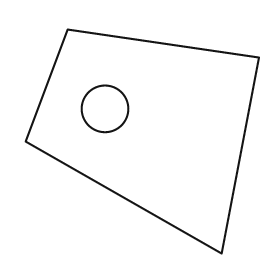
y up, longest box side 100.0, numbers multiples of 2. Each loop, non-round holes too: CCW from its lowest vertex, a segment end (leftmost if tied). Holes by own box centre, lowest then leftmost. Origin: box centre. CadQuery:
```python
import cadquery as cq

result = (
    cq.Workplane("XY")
    .moveTo(34.0, -48.0)
    .lineTo(50.0, 36.0)
    .lineTo(-32.0, 48.0)
    .lineTo(-50.0, 0.0)
    .close()
    .moveTo(-16.0, 14.0)
    .circle(10.0)
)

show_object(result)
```